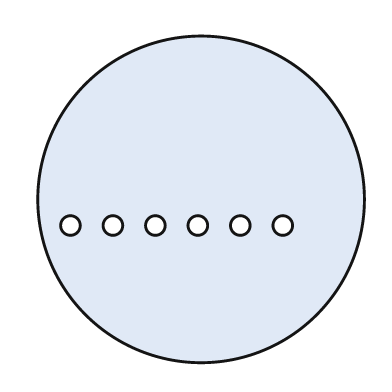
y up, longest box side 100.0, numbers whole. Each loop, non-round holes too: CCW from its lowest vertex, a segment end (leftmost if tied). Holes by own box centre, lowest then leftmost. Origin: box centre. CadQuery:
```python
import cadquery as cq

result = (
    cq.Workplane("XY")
    .moveTo(0.0, 0.0)
    .circle(50.0)
    .moveTo(-40.0, -8.0)
    .circle(3.0)
    .moveTo(-27.0, -8.0)
    .circle(3.0)
    .moveTo(-14.0, -8.0)
    .circle(3.0)
    .moveTo(-1.0, -8.0)
    .circle(3.0)
    .moveTo(12.0, -8.0)
    .circle(3.0)
    .moveTo(25.0, -8.0)
    .circle(3.0)
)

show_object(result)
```